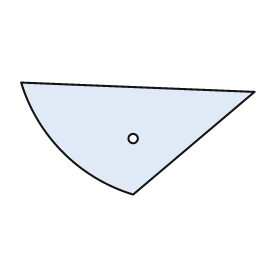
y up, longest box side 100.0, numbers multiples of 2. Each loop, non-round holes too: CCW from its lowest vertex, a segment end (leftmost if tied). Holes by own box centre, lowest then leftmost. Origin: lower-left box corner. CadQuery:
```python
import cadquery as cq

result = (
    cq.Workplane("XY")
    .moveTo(48.0, 0.0)
    .lineTo(100.0, 44.0)
    .lineTo(0.0, 48.0)
    .threePointArc((18.0, 18.0), (48.0, 0.0))
    .close()
    .moveTo(48.0, 24.0)
    .circle(2.0)
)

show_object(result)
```